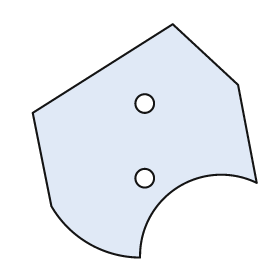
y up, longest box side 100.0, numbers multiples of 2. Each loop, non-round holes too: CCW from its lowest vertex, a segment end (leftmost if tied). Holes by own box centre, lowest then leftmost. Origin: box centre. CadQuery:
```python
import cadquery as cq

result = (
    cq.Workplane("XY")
    .moveTo(-2.0, -50.0)
    .threePointArc((14.0, -20.0), (48.0, -18.0))
    .lineTo(40.0, 24.0)
    .lineTo(12.0, 50.0)
    .lineTo(-48.0, 12.0)
    .lineTo(-40.0, -28.0)
    .threePointArc((-24.0, -44.0), (-2.0, -50.0))
    .close()
    .moveTo(0.0, -16.0)
    .circle(4.0)
    .moveTo(0.0, 16.0)
    .circle(4.0)
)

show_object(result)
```